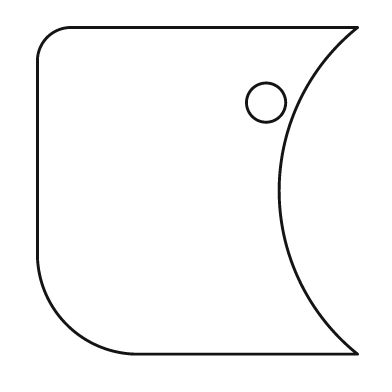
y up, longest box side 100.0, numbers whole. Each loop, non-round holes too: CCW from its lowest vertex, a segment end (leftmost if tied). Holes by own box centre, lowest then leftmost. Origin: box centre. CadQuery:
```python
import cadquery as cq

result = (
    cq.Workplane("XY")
    .moveTo(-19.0, -50.0)
    .lineTo(49.0, -50.0)
    .threePointArc((25.0, 0.0), (49.0, 50.0))
    .lineTo(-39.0, 50.0)
    .threePointArc((-46.0, 47.0), (-49.0, 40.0))
    .lineTo(-49.0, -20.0)
    .threePointArc((-40.0, -41.0), (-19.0, -50.0))
    .close()
    .moveTo(21.0, 27.0)
    .circle(6.0)
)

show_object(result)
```